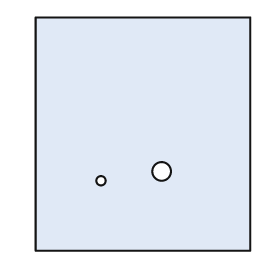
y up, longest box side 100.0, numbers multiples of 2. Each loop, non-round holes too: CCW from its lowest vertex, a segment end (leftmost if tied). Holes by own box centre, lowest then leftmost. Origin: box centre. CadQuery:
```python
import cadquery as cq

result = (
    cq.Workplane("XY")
    .moveTo(-46.0, -50.0)
    .lineTo(46.0, -50.0)
    .lineTo(46.0, 50.0)
    .lineTo(-46.0, 50.0)
    .close()
    .moveTo(-18.0, -20.0)
    .circle(2.0)
    .moveTo(8.0, -16.0)
    .circle(4.0)
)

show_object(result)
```